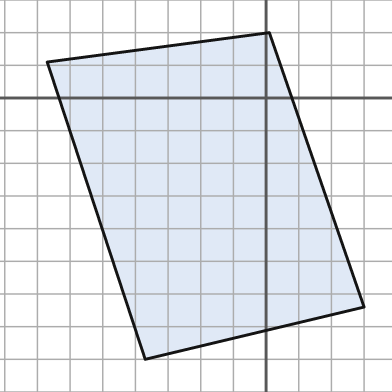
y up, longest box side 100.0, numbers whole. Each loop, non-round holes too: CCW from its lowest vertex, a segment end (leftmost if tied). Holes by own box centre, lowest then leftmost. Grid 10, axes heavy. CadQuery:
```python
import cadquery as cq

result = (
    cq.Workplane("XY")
    .moveTo(-37.0, -80.0)
    .lineTo(30.0, -64.0)
    .lineTo(1.0, 20.0)
    .lineTo(-67.0, 11.0)
    .close()
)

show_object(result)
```